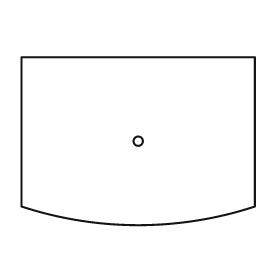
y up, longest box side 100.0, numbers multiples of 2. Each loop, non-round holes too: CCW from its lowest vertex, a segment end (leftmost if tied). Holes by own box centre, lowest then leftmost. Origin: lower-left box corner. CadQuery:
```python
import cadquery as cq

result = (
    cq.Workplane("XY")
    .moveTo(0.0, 8.0)
    .threePointArc((50.0, 0.0), (100.0, 8.0))
    .lineTo(100.0, 72.0)
    .lineTo(0.0, 72.0)
    .close()
    .moveTo(50.0, 36.0)
    .circle(2.0)
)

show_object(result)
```